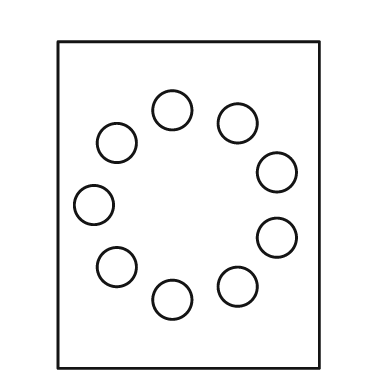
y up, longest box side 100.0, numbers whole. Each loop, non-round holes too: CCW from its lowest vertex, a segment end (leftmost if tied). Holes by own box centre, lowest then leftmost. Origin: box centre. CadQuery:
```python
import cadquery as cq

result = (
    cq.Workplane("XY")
    .moveTo(-40.0, -50.0)
    .lineTo(40.0, -50.0)
    .lineTo(40.0, 50.0)
    .lineTo(-40.0, 50.0)
    .close()
    .moveTo(-5.0, -29.0)
    .circle(6.0)
    .moveTo(15.0, -25.0)
    .circle(6.0)
    .moveTo(-22.0, -19.0)
    .circle(6.0)
    .moveTo(27.0, -10.0)
    .circle(6.0)
    .moveTo(-29.0, 0.0)
    .circle(6.0)
    .moveTo(27.0, 10.0)
    .circle(6.0)
    .moveTo(-22.0, 19.0)
    .circle(6.0)
    .moveTo(15.0, 25.0)
    .circle(6.0)
    .moveTo(-5.0, 29.0)
    .circle(6.0)
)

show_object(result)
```